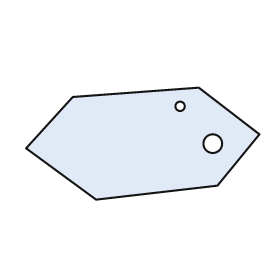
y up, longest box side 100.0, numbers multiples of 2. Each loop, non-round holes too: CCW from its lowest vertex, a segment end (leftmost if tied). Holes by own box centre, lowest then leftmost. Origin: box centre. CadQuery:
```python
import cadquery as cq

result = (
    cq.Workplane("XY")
    .moveTo(-20.0, -24.0)
    .lineTo(32.0, -18.0)
    .lineTo(50.0, 4.0)
    .lineTo(24.0, 24.0)
    .lineTo(-30.0, 20.0)
    .lineTo(-50.0, -2.0)
    .close()
    .moveTo(30.0, 0.0)
    .circle(4.0)
    .moveTo(16.0, 16.0)
    .circle(2.0)
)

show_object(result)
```